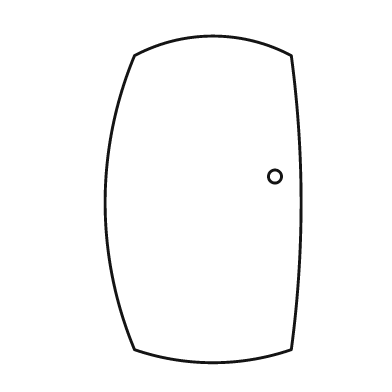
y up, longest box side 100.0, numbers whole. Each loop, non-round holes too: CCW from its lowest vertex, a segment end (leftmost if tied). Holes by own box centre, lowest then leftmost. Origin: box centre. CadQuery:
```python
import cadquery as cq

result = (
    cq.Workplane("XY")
    .moveTo(-21.0, -46.0)
    .threePointArc((3.0, -50.0), (27.0, -46.0))
    .threePointArc((30.0, -1.0), (27.0, 44.0))
    .threePointArc((3.0, 50.0), (-21.0, 44.0))
    .threePointArc((-30.0, -1.0), (-21.0, -46.0))
    .close()
    .moveTo(22.0, 7.0)
    .circle(2.0)
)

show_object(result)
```